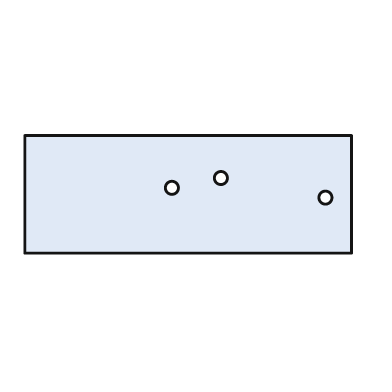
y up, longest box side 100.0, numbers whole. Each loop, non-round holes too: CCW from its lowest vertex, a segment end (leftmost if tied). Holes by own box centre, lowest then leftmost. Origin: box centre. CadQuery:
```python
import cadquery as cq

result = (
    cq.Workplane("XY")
    .moveTo(-50.0, -18.0)
    .lineTo(50.0, -18.0)
    .lineTo(50.0, 18.0)
    .lineTo(-50.0, 18.0)
    .close()
    .moveTo(42.0, -1.0)
    .circle(2.0)
    .moveTo(-5.0, 2.0)
    .circle(2.0)
    .moveTo(10.0, 5.0)
    .circle(2.0)
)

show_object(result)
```